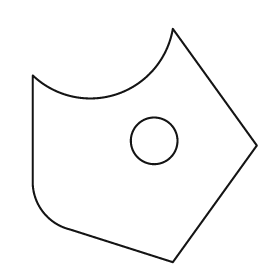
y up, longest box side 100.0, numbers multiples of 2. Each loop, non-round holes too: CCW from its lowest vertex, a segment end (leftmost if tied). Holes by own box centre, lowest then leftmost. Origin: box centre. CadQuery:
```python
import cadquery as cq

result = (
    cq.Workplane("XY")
    .moveTo(12.0, -50.0)
    .lineTo(48.0, 0.0)
    .lineTo(12.0, 50.0)
    .threePointArc((-12.0, 22.0), (-48.0, 30.0))
    .lineTo(-48.0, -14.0)
    .threePointArc((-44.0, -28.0), (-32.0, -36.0))
    .close()
    .moveTo(4.0, 2.0)
    .circle(10.0)
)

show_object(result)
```